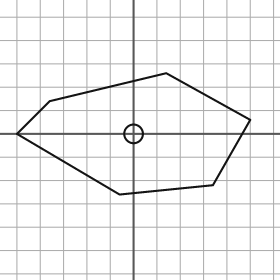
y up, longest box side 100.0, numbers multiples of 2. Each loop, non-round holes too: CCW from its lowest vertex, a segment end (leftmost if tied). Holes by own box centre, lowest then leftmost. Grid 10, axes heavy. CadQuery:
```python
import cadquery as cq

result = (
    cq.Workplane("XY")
    .moveTo(-6.0, -26.0)
    .lineTo(34.0, -22.0)
    .lineTo(50.0, 6.0)
    .lineTo(14.0, 26.0)
    .lineTo(-36.0, 14.0)
    .lineTo(-50.0, 0.0)
    .close()
    .moveTo(0.0, 0.0)
    .circle(4.0)
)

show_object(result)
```